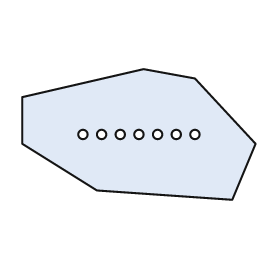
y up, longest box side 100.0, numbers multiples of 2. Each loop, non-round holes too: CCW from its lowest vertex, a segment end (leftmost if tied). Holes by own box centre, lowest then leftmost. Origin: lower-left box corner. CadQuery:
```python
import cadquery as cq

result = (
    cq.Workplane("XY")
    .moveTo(90.0, 0.0)
    .lineTo(100.0, 24.0)
    .lineTo(74.0, 52.0)
    .lineTo(52.0, 56.0)
    .lineTo(0.0, 44.0)
    .lineTo(0.0, 24.0)
    .lineTo(32.0, 4.0)
    .close()
    .moveTo(26.0, 28.0)
    .circle(2.0)
    .moveTo(34.0, 28.0)
    .circle(2.0)
    .moveTo(42.0, 28.0)
    .circle(2.0)
    .moveTo(50.0, 28.0)
    .circle(2.0)
    .moveTo(58.0, 28.0)
    .circle(2.0)
    .moveTo(66.0, 28.0)
    .circle(2.0)
    .moveTo(74.0, 28.0)
    .circle(2.0)
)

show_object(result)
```